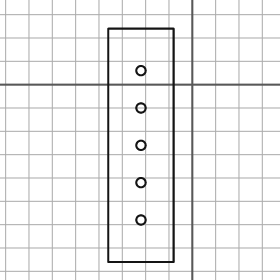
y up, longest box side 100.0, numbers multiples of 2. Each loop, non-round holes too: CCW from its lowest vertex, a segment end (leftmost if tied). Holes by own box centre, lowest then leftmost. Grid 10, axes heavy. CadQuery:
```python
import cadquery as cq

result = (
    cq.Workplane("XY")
    .moveTo(-36.0, -76.0)
    .lineTo(-8.0, -76.0)
    .lineTo(-8.0, 24.0)
    .lineTo(-36.0, 24.0)
    .close()
    .moveTo(-22.0, -58.0)
    .circle(2.0)
    .moveTo(-22.0, -42.0)
    .circle(2.0)
    .moveTo(-22.0, -26.0)
    .circle(2.0)
    .moveTo(-22.0, -10.0)
    .circle(2.0)
    .moveTo(-22.0, 6.0)
    .circle(2.0)
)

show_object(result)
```